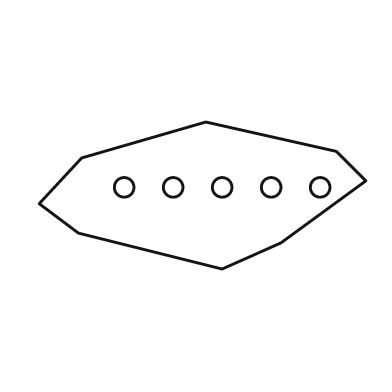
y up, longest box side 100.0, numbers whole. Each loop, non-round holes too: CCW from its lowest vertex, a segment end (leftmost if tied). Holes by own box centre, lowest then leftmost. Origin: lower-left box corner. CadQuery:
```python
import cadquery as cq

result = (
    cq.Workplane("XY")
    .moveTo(56.0, 0.0)
    .lineTo(74.0, 8.0)
    .lineTo(100.0, 27.0)
    .lineTo(91.0, 36.0)
    .lineTo(51.0, 45.0)
    .lineTo(13.0, 34.0)
    .lineTo(0.0, 20.0)
    .lineTo(12.0, 11.0)
    .close()
    .moveTo(26.0, 25.0)
    .circle(3.0)
    .moveTo(41.0, 25.0)
    .circle(3.0)
    .moveTo(56.0, 25.0)
    .circle(3.0)
    .moveTo(71.0, 25.0)
    .circle(3.0)
    .moveTo(86.0, 25.0)
    .circle(3.0)
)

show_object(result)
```